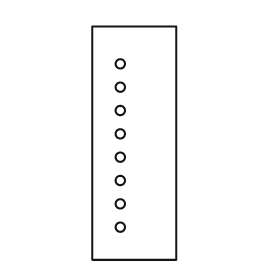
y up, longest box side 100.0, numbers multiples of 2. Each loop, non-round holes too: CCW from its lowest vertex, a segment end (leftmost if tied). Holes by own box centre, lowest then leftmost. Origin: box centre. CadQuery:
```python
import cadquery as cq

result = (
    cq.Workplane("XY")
    .moveTo(-18.0, -50.0)
    .lineTo(18.0, -50.0)
    .lineTo(18.0, 50.0)
    .lineTo(-18.0, 50.0)
    .close()
    .moveTo(-6.0, -36.0)
    .circle(2.0)
    .moveTo(-6.0, -26.0)
    .circle(2.0)
    .moveTo(-6.0, -16.0)
    .circle(2.0)
    .moveTo(-6.0, -6.0)
    .circle(2.0)
    .moveTo(-6.0, 4.0)
    .circle(2.0)
    .moveTo(-6.0, 14.0)
    .circle(2.0)
    .moveTo(-6.0, 24.0)
    .circle(2.0)
    .moveTo(-6.0, 34.0)
    .circle(2.0)
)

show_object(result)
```